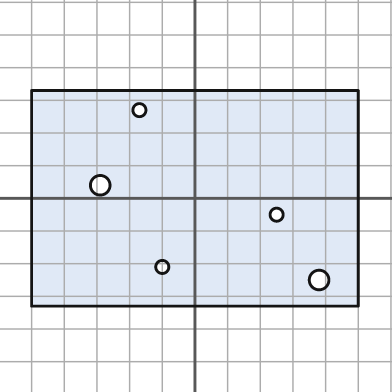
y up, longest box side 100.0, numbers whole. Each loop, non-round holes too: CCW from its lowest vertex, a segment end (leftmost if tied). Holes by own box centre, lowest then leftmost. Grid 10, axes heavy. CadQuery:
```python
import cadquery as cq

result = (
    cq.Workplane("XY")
    .moveTo(-50.0, -33.0)
    .lineTo(50.0, -33.0)
    .lineTo(50.0, 33.0)
    .lineTo(-50.0, 33.0)
    .close()
    .moveTo(38.0, -25.0)
    .circle(3.0)
    .moveTo(-10.0, -21.0)
    .circle(2.0)
    .moveTo(25.0, -5.0)
    .circle(2.0)
    .moveTo(-29.0, 4.0)
    .circle(3.0)
    .moveTo(-17.0, 27.0)
    .circle(2.0)
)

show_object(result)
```